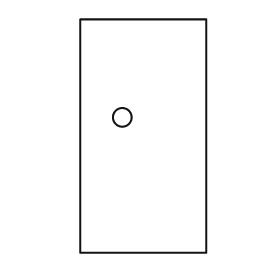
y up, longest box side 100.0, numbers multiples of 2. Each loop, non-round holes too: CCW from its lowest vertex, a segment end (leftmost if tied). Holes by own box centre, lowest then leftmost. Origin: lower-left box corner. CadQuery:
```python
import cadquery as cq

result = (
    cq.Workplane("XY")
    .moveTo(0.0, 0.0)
    .lineTo(54.0, 0.0)
    .lineTo(54.0, 100.0)
    .lineTo(0.0, 100.0)
    .close()
    .moveTo(18.0, 58.0)
    .circle(4.0)
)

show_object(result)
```